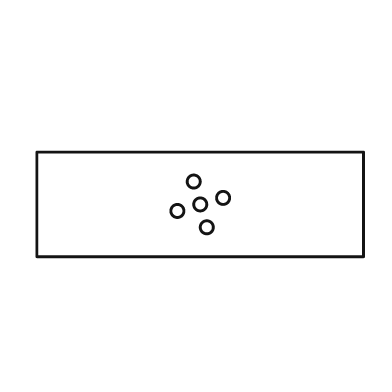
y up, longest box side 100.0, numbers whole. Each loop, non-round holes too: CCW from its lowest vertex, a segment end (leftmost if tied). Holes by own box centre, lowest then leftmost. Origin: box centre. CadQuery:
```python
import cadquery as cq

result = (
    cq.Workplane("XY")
    .moveTo(-50.0, -16.0)
    .lineTo(50.0, -16.0)
    .lineTo(50.0, 16.0)
    .lineTo(-50.0, 16.0)
    .close()
    .moveTo(2.0, -7.0)
    .circle(2.0)
    .moveTo(-7.0, -2.0)
    .circle(2.0)
    .moveTo(0.0, 0.0)
    .circle(2.0)
    .moveTo(7.0, 2.0)
    .circle(2.0)
    .moveTo(-2.0, 7.0)
    .circle(2.0)
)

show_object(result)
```